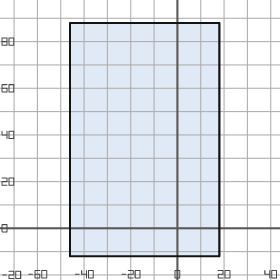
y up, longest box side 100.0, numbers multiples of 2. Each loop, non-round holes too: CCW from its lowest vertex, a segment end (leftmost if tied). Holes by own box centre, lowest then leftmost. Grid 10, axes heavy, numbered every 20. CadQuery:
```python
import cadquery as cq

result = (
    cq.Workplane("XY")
    .moveTo(-46.0, -12.0)
    .lineTo(18.0, -12.0)
    .lineTo(18.0, 88.0)
    .lineTo(-46.0, 88.0)
    .close()
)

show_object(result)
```